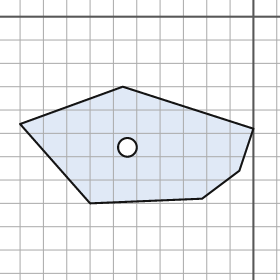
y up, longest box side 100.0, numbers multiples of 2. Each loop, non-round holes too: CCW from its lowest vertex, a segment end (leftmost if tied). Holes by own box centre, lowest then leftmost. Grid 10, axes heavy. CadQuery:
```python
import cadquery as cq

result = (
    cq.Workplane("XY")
    .moveTo(-70.0, -80.0)
    .lineTo(-22.0, -78.0)
    .lineTo(-6.0, -66.0)
    .lineTo(0.0, -48.0)
    .lineTo(-56.0, -30.0)
    .lineTo(-100.0, -46.0)
    .close()
    .moveTo(-54.0, -56.0)
    .circle(4.0)
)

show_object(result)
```